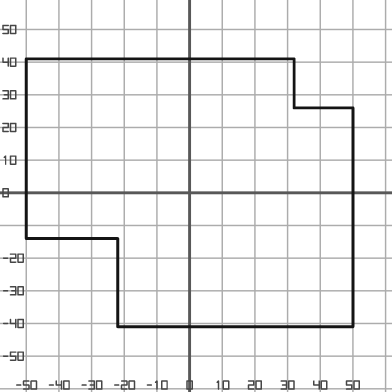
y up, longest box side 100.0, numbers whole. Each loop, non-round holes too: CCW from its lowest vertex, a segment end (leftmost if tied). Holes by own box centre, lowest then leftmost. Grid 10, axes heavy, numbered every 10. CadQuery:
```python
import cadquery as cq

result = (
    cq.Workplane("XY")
    .moveTo(-22.0, -41.0)
    .lineTo(50.0, -41.0)
    .lineTo(50.0, 26.0)
    .lineTo(32.0, 26.0)
    .lineTo(32.0, 41.0)
    .lineTo(-50.0, 41.0)
    .lineTo(-50.0, -14.0)
    .lineTo(-22.0, -14.0)
    .close()
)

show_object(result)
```